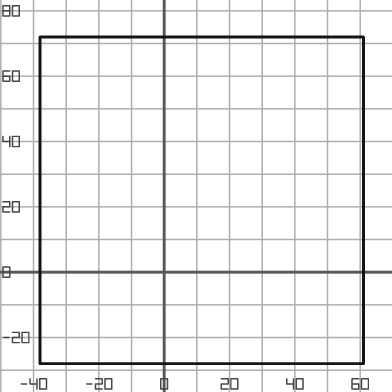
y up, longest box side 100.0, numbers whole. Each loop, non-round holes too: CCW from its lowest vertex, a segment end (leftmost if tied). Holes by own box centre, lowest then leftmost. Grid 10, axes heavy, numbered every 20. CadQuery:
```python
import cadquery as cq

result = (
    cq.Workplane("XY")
    .moveTo(-38.0, -28.0)
    .lineTo(61.0, -28.0)
    .lineTo(61.0, 72.0)
    .lineTo(-38.0, 72.0)
    .close()
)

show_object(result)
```